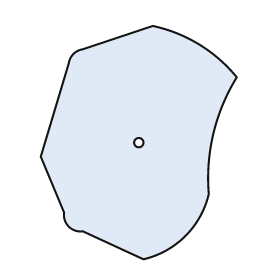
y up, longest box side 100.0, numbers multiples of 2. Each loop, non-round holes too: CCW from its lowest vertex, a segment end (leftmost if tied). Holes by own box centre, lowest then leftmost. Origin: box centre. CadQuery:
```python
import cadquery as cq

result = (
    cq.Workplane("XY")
    .moveTo(2.0, -50.0)
    .threePointArc((20.0, -40.0), (30.0, -22.0))
    .threePointArc((32.0, 4.0), (42.0, 28.0))
    .threePointArc((26.0, 42.0), (6.0, 50.0))
    .lineTo(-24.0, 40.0)
    .threePointArc((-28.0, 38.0), (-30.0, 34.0))
    .lineTo(-42.0, -6.0)
    .lineTo(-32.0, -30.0)
    .threePointArc((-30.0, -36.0), (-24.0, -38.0))
    .close()
    .moveTo(0.0, 0.0)
    .circle(2.0)
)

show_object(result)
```